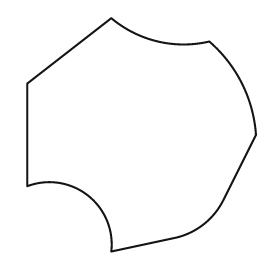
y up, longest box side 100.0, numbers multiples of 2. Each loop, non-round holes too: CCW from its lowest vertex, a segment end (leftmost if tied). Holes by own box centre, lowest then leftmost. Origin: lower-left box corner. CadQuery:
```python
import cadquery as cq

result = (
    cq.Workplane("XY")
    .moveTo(36.0, 0.0)
    .lineTo(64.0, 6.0)
    .threePointArc((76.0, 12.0), (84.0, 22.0))
    .lineTo(98.0, 50.0)
    .threePointArc((92.0, 72.0), (78.0, 90.0))
    .threePointArc((56.0, 90.0), (36.0, 100.0))
    .lineTo(0.0, 72.0)
    .lineTo(0.0, 28.0)
    .threePointArc((26.0, 24.0), (36.0, 0.0))
    .close()
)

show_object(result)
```